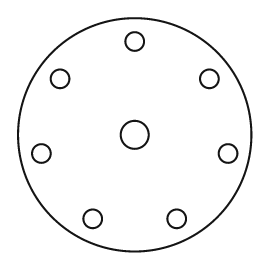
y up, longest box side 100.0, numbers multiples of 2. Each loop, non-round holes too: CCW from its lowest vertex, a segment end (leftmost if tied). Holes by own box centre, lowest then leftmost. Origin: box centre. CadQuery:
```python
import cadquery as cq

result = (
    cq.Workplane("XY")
    .moveTo(0.0, 0.0)
    .circle(50.0)
    .moveTo(-18.0, -36.0)
    .circle(4.0)
    .moveTo(18.0, -36.0)
    .circle(4.0)
    .moveTo(-40.0, -8.0)
    .circle(4.0)
    .moveTo(40.0, -8.0)
    .circle(4.0)
    .moveTo(0.0, 0.0)
    .circle(6.0)
    .moveTo(-32.0, 24.0)
    .circle(4.0)
    .moveTo(32.0, 24.0)
    .circle(4.0)
    .moveTo(0.0, 40.0)
    .circle(4.0)
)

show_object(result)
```